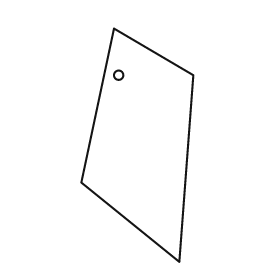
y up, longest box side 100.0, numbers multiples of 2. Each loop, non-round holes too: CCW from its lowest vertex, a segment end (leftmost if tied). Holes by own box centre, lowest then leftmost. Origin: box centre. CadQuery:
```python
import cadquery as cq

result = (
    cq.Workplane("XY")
    .moveTo(18.0, -50.0)
    .lineTo(24.0, 30.0)
    .lineTo(-10.0, 50.0)
    .lineTo(-24.0, -16.0)
    .close()
    .moveTo(-8.0, 30.0)
    .circle(2.0)
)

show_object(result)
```